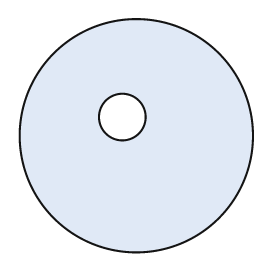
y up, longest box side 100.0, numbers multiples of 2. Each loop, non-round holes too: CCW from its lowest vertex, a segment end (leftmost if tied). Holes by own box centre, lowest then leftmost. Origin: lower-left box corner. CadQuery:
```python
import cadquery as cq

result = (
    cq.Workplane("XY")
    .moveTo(50.0, 50.0)
    .circle(50.0)
    .moveTo(44.0, 58.0)
    .circle(10.0)
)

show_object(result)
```